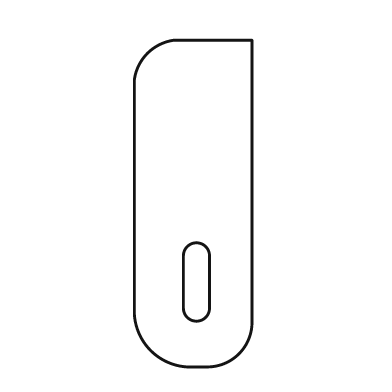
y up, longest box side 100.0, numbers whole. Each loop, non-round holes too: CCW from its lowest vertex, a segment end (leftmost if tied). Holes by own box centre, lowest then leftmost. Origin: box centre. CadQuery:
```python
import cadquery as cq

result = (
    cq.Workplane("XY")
    .moveTo(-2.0, -50.0)
    .lineTo(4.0, -50.0)
    .threePointArc((14.0, -46.0), (18.0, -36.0))
    .lineTo(18.0, 50.0)
    .lineTo(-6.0, 50.0)
    .threePointArc((-14.0, 46.0), (-18.0, 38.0))
    .lineTo(-18.0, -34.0)
    .threePointArc((-13.0, -45.0), (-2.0, -50.0))
    .close()
    .moveTo(-3.0, -32.0)
    .threePointArc((1.0, -36.0), (5.0, -32.0))
    .lineTo(5.0, -16.0)
    .threePointArc((1.0, -12.0), (-3.0, -16.0))
    .close()
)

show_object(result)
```